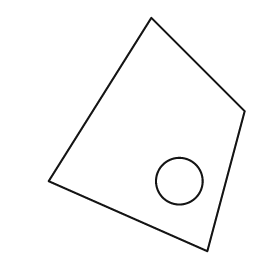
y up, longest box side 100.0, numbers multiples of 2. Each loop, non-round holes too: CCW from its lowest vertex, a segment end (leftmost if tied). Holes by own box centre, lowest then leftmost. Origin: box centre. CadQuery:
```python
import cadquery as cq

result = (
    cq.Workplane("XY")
    .moveTo(26.0, -50.0)
    .lineTo(42.0, 10.0)
    .lineTo(2.0, 50.0)
    .lineTo(-42.0, -20.0)
    .close()
    .moveTo(14.0, -20.0)
    .circle(10.0)
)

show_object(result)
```